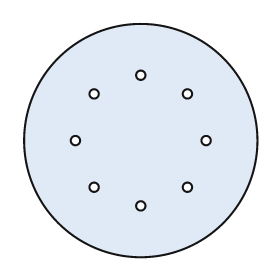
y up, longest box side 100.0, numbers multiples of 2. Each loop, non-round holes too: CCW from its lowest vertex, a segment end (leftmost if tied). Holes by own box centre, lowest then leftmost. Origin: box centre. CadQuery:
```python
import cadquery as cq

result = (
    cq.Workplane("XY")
    .moveTo(0.0, 0.0)
    .circle(50.0)
    .moveTo(0.0, -28.0)
    .circle(2.0)
    .moveTo(-20.0, -20.0)
    .circle(2.0)
    .moveTo(20.0, -20.0)
    .circle(2.0)
    .moveTo(-28.0, 0.0)
    .circle(2.0)
    .moveTo(28.0, 0.0)
    .circle(2.0)
    .moveTo(-20.0, 20.0)
    .circle(2.0)
    .moveTo(20.0, 20.0)
    .circle(2.0)
    .moveTo(0.0, 28.0)
    .circle(2.0)
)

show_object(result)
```